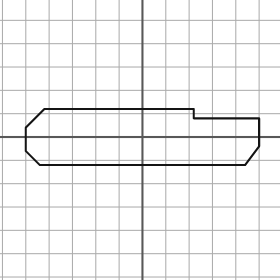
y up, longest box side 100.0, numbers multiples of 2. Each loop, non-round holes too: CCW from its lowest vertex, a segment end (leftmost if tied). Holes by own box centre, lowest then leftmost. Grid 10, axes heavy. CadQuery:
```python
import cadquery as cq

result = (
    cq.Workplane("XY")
    .moveTo(-44.0, -12.0)
    .lineTo(44.0, -12.0)
    .lineTo(50.0, -4.0)
    .lineTo(50.0, 8.0)
    .lineTo(22.0, 8.0)
    .lineTo(22.0, 12.0)
    .lineTo(-42.0, 12.0)
    .lineTo(-50.0, 4.0)
    .lineTo(-50.0, -6.0)
    .close()
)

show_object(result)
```